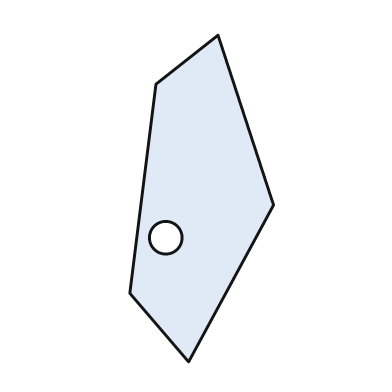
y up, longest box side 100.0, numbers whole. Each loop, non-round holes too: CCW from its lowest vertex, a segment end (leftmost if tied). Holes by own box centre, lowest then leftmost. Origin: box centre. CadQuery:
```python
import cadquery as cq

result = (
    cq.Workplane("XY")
    .moveTo(-4.0, -50.0)
    .lineTo(22.0, -2.0)
    .lineTo(5.0, 50.0)
    .lineTo(-14.0, 35.0)
    .lineTo(-22.0, -29.0)
    .close()
    .moveTo(-11.0, -12.0)
    .circle(5.0)
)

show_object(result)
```